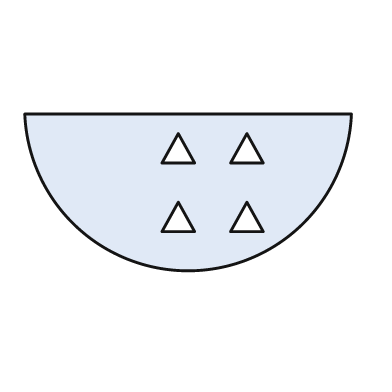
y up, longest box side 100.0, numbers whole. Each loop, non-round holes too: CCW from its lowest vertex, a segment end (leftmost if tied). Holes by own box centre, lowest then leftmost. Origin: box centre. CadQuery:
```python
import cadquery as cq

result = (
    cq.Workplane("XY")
    .moveTo(-50.0, 24.0)
    .threePointArc((0.0, -24.0), (50.0, 24.0))
    .close()
    .moveTo(-8.0, -12.0)
    .lineTo(2.0, -12.0)
    .lineTo(-3.0, -3.0)
    .close()
    .moveTo(13.0, -12.0)
    .lineTo(23.0, -12.0)
    .lineTo(18.0, -3.0)
    .close()
    .moveTo(-8.0, 9.0)
    .lineTo(2.0, 9.0)
    .lineTo(-3.0, 18.0)
    .close()
    .moveTo(13.0, 9.0)
    .lineTo(23.0, 9.0)
    .lineTo(18.0, 18.0)
    .close()
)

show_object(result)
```